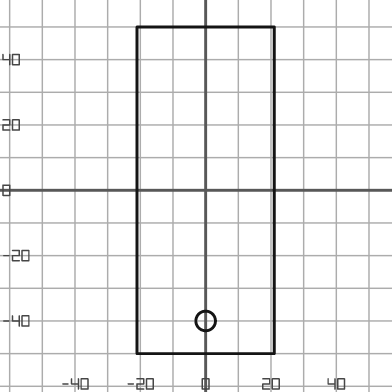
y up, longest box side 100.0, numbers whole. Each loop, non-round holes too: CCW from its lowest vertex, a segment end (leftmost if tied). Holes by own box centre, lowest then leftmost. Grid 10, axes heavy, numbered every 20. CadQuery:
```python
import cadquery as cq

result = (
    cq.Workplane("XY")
    .moveTo(-21.0, -50.0)
    .lineTo(21.0, -50.0)
    .lineTo(21.0, 50.0)
    .lineTo(-21.0, 50.0)
    .close()
    .moveTo(0.0, -40.0)
    .circle(3.0)
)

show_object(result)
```